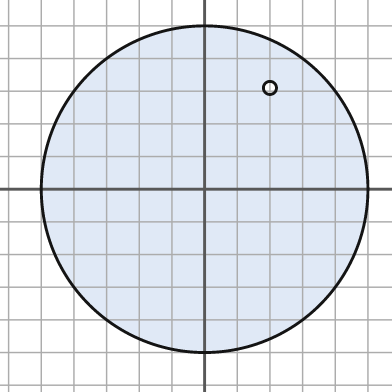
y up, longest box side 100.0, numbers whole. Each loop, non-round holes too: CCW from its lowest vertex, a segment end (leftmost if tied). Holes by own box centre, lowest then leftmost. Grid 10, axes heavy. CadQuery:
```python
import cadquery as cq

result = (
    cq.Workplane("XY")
    .moveTo(0.0, 0.0)
    .circle(50.0)
    .moveTo(20.0, 31.0)
    .circle(2.0)
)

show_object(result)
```